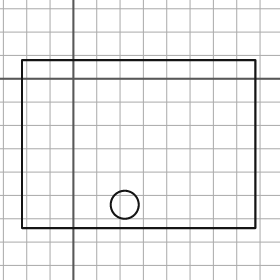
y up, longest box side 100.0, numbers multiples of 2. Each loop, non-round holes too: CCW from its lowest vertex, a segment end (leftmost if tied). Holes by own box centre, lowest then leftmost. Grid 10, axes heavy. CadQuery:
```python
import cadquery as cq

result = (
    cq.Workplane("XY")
    .moveTo(-22.0, -64.0)
    .lineTo(78.0, -64.0)
    .lineTo(78.0, 8.0)
    .lineTo(-22.0, 8.0)
    .close()
    .moveTo(22.0, -54.0)
    .circle(6.0)
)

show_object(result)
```